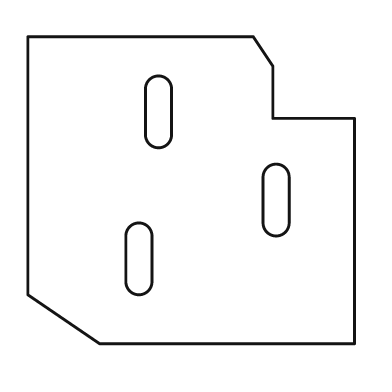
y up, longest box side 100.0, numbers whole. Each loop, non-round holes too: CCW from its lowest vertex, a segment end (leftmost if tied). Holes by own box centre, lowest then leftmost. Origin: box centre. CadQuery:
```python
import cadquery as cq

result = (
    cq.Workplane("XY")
    .moveTo(-28.0, -47.0)
    .lineTo(50.0, -47.0)
    .lineTo(50.0, 22.0)
    .lineTo(25.0, 22.0)
    .lineTo(25.0, 38.0)
    .lineTo(19.0, 47.0)
    .lineTo(-50.0, 47.0)
    .lineTo(-50.0, -32.0)
    .close()
    .moveTo(-20.0, -28.0)
    .threePointArc((-16.0, -32.0), (-12.0, -28.0))
    .lineTo(-12.0, -14.0)
    .threePointArc((-16.0, -10.0), (-20.0, -14.0))
    .close()
    .moveTo(22.0, -10.0)
    .threePointArc((26.0, -14.0), (30.0, -10.0))
    .lineTo(30.0, 4.0)
    .threePointArc((26.0, 8.0), (22.0, 4.0))
    .close()
    .moveTo(-14.0, 17.0)
    .threePointArc((-10.0, 13.0), (-6.0, 17.0))
    .lineTo(-6.0, 31.0)
    .threePointArc((-10.0, 35.0), (-14.0, 31.0))
    .close()
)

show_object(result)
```